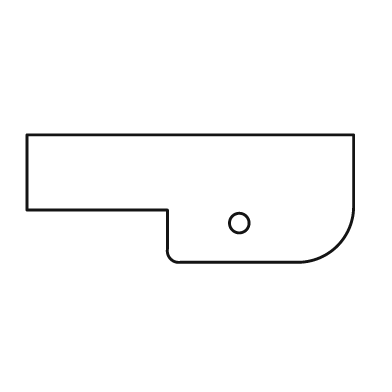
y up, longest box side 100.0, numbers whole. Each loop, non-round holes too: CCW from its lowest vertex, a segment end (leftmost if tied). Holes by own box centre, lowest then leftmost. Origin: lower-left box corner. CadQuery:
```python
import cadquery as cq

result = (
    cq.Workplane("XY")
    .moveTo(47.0, 0.0)
    .lineTo(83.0, 0.0)
    .threePointArc((95.0, 5.0), (100.0, 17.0))
    .lineTo(100.0, 39.0)
    .lineTo(0.0, 39.0)
    .lineTo(0.0, 16.0)
    .lineTo(43.0, 16.0)
    .lineTo(43.0, 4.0)
    .threePointArc((44.0, 1.0), (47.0, 0.0))
    .close()
    .moveTo(65.0, 12.0)
    .circle(3.0)
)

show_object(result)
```